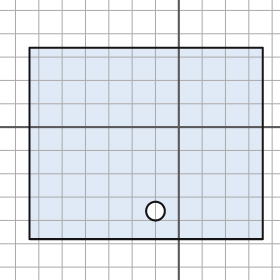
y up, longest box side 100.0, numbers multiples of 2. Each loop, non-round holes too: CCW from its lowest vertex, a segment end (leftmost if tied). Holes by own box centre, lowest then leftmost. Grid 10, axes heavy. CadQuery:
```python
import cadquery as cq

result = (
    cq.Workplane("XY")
    .moveTo(-64.0, -48.0)
    .lineTo(36.0, -48.0)
    .lineTo(36.0, 34.0)
    .lineTo(-64.0, 34.0)
    .close()
    .moveTo(-10.0, -36.0)
    .circle(4.0)
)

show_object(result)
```